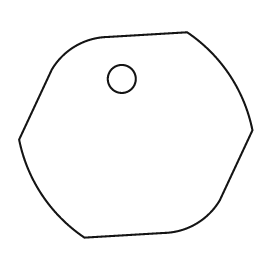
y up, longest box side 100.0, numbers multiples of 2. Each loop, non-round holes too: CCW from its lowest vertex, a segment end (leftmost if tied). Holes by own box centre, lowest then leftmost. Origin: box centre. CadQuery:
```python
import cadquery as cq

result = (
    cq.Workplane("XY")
    .moveTo(-22.0, -44.0)
    .lineTo(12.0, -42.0)
    .threePointArc((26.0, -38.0), (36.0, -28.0))
    .lineTo(50.0, 2.0)
    .threePointArc((40.0, 26.0), (22.0, 44.0))
    .lineTo(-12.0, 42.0)
    .threePointArc((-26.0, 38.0), (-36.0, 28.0))
    .lineTo(-50.0, -2.0)
    .threePointArc((-40.0, -26.0), (-22.0, -44.0))
    .close()
    .moveTo(-6.0, 24.0)
    .circle(6.0)
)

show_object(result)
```